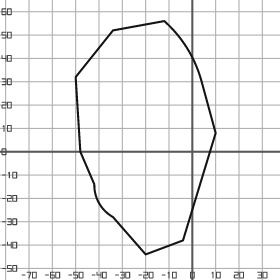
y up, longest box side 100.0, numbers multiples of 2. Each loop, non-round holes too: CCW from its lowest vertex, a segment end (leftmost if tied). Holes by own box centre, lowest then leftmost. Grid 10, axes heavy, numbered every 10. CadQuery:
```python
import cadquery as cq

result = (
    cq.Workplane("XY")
    .moveTo(-20.0, -44.0)
    .lineTo(-4.0, -38.0)
    .lineTo(10.0, 8.0)
    .lineTo(4.0, 30.0)
    .threePointArc((-2.0, 44.0), (-12.0, 56.0))
    .lineTo(-34.0, 52.0)
    .lineTo(-50.0, 32.0)
    .lineTo(-48.0, 0.0)
    .lineTo(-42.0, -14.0)
    .threePointArc((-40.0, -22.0), (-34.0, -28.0))
    .close()
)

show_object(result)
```